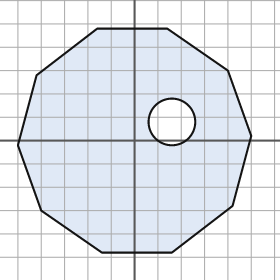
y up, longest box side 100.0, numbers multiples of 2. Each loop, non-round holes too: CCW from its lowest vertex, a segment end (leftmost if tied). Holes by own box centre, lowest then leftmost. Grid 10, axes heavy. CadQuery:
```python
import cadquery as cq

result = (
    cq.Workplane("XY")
    .moveTo(-14.0, -48.0)
    .lineTo(16.0, -48.0)
    .lineTo(42.0, -28.0)
    .lineTo(50.0, 2.0)
    .lineTo(40.0, 30.0)
    .lineTo(14.0, 48.0)
    .lineTo(-16.0, 48.0)
    .lineTo(-42.0, 28.0)
    .lineTo(-50.0, -2.0)
    .lineTo(-40.0, -30.0)
    .close()
    .moveTo(16.0, 8.0)
    .circle(10.0)
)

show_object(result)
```